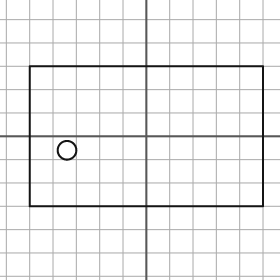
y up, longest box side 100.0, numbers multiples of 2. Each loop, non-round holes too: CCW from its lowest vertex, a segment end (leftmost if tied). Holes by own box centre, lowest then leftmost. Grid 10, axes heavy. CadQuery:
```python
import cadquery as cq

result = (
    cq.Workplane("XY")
    .moveTo(-50.0, -30.0)
    .lineTo(50.0, -30.0)
    .lineTo(50.0, 30.0)
    .lineTo(-50.0, 30.0)
    .close()
    .moveTo(-34.0, -6.0)
    .circle(4.0)
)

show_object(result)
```